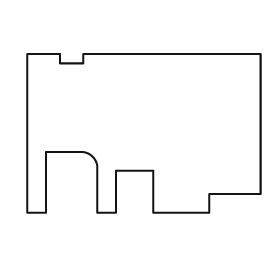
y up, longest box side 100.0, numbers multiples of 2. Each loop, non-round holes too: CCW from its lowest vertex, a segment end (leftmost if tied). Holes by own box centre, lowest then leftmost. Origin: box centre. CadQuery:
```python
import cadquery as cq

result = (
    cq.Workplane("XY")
    .moveTo(-50.0, -34.0)
    .lineTo(-42.0, -34.0)
    .lineTo(-42.0, -8.0)
    .lineTo(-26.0, -8.0)
    .threePointArc((-22.0, -10.0), (-20.0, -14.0))
    .lineTo(-20.0, -34.0)
    .lineTo(-12.0, -34.0)
    .lineTo(-12.0, -16.0)
    .lineTo(4.0, -16.0)
    .lineTo(4.0, -34.0)
    .lineTo(28.0, -34.0)
    .lineTo(28.0, -26.0)
    .lineTo(50.0, -26.0)
    .lineTo(50.0, 34.0)
    .lineTo(-26.0, 34.0)
    .lineTo(-26.0, 30.0)
    .lineTo(-36.0, 30.0)
    .lineTo(-36.0, 34.0)
    .lineTo(-50.0, 34.0)
    .close()
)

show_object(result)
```